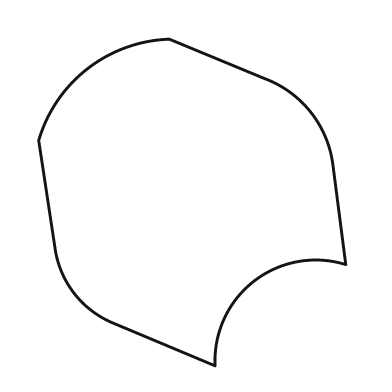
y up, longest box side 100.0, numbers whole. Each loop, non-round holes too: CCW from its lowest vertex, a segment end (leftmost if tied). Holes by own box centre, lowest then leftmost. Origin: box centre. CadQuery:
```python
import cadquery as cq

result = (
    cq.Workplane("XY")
    .moveTo(7.0, -50.0)
    .threePointArc((19.0, -24.0), (47.0, -19.0))
    .lineTo(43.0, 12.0)
    .threePointArc((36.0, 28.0), (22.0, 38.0))
    .lineTo(-7.0, 50.0)
    .threePointArc((-32.0, 41.0), (-47.0, 19.0))
    .lineTo(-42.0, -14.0)
    .threePointArc((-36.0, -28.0), (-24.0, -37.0))
    .close()
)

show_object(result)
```